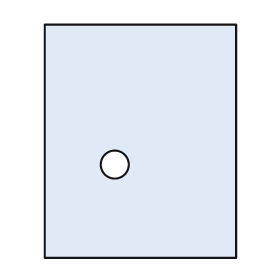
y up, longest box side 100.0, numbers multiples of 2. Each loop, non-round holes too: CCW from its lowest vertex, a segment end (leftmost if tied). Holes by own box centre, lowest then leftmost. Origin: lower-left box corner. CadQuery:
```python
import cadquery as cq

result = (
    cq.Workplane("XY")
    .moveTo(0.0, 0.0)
    .lineTo(82.0, 0.0)
    .lineTo(82.0, 100.0)
    .lineTo(0.0, 100.0)
    .close()
    .moveTo(30.0, 40.0)
    .circle(6.0)
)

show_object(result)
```